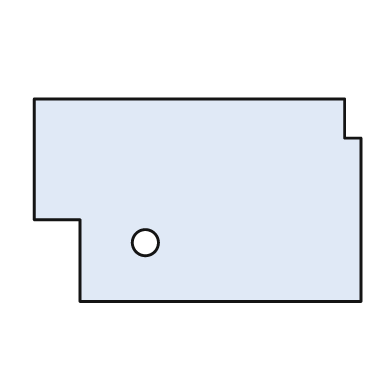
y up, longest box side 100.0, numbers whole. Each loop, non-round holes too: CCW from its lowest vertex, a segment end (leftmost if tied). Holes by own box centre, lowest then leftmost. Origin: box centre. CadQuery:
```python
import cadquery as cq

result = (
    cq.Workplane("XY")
    .moveTo(-36.0, -31.0)
    .lineTo(50.0, -31.0)
    .lineTo(50.0, 19.0)
    .lineTo(45.0, 19.0)
    .lineTo(45.0, 31.0)
    .lineTo(-50.0, 31.0)
    .lineTo(-50.0, -6.0)
    .lineTo(-36.0, -6.0)
    .close()
    .moveTo(-16.0, -13.0)
    .circle(4.0)
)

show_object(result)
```